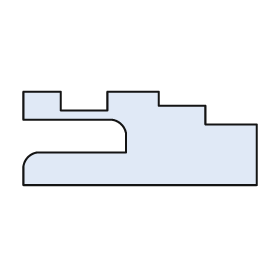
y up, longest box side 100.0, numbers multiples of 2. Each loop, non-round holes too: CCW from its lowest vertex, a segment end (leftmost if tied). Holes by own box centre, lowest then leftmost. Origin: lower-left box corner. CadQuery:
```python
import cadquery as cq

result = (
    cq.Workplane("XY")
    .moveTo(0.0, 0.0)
    .lineTo(100.0, 0.0)
    .lineTo(100.0, 26.0)
    .lineTo(78.0, 26.0)
    .lineTo(78.0, 34.0)
    .lineTo(58.0, 34.0)
    .lineTo(58.0, 40.0)
    .lineTo(36.0, 40.0)
    .lineTo(36.0, 32.0)
    .lineTo(16.0, 32.0)
    .lineTo(16.0, 40.0)
    .lineTo(0.0, 40.0)
    .lineTo(0.0, 28.0)
    .lineTo(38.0, 28.0)
    .threePointArc((42.0, 26.0), (44.0, 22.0))
    .lineTo(44.0, 14.0)
    .lineTo(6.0, 14.0)
    .threePointArc((2.0, 12.0), (0.0, 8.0))
    .close()
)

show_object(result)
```